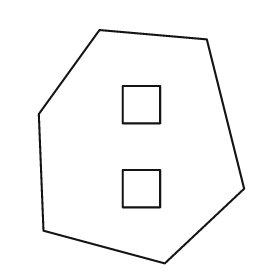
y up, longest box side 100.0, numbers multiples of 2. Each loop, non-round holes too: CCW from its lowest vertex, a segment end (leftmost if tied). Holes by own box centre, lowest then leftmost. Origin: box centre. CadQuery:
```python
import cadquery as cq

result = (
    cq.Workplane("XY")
    .moveTo(10.0, -50.0)
    .lineTo(44.0, -18.0)
    .lineTo(28.0, 46.0)
    .lineTo(-18.0, 50.0)
    .lineTo(-44.0, 14.0)
    .lineTo(-42.0, -36.0)
    .close()
    .moveTo(-8.0, -26.0)
    .lineTo(8.0, -26.0)
    .lineTo(8.0, -10.0)
    .lineTo(-8.0, -10.0)
    .close()
    .moveTo(-8.0, 10.0)
    .lineTo(8.0, 10.0)
    .lineTo(8.0, 26.0)
    .lineTo(-8.0, 26.0)
    .close()
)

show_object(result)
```